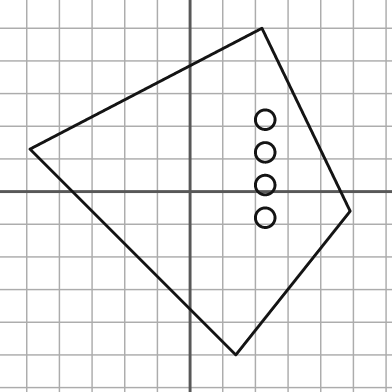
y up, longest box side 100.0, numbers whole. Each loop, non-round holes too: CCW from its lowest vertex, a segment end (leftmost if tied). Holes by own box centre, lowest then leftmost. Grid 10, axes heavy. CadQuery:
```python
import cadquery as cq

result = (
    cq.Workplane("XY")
    .moveTo(14.0, -50.0)
    .lineTo(49.0, -6.0)
    .lineTo(22.0, 50.0)
    .lineTo(-49.0, 13.0)
    .close()
    .moveTo(23.0, -8.0)
    .circle(3.0)
    .moveTo(23.0, 2.0)
    .circle(3.0)
    .moveTo(23.0, 12.0)
    .circle(3.0)
    .moveTo(23.0, 22.0)
    .circle(3.0)
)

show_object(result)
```